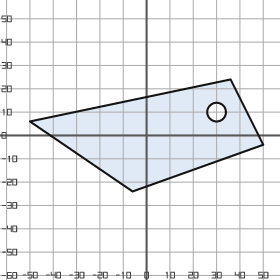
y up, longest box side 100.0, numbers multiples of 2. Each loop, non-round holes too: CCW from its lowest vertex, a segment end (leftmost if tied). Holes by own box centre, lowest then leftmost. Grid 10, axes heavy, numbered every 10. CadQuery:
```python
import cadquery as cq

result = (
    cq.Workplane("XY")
    .moveTo(-6.0, -24.0)
    .lineTo(50.0, -4.0)
    .lineTo(36.0, 24.0)
    .lineTo(-50.0, 6.0)
    .close()
    .moveTo(30.0, 10.0)
    .circle(4.0)
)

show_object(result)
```